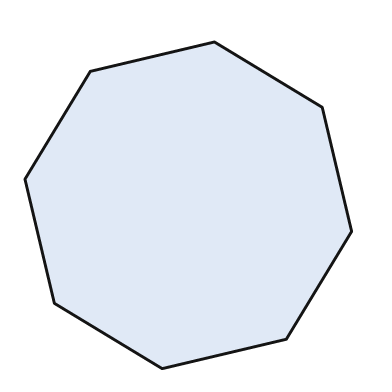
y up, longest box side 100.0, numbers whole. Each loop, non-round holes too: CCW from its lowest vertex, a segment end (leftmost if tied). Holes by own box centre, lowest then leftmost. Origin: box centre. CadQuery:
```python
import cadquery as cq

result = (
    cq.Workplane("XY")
    .moveTo(-8.0, -50.0)
    .lineTo(30.0, -41.0)
    .lineTo(50.0, -8.0)
    .lineTo(41.0, 30.0)
    .lineTo(8.0, 50.0)
    .lineTo(-30.0, 41.0)
    .lineTo(-50.0, 8.0)
    .lineTo(-41.0, -30.0)
    .close()
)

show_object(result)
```